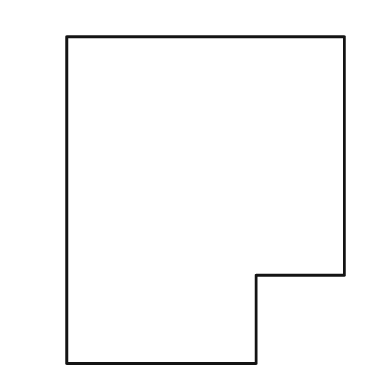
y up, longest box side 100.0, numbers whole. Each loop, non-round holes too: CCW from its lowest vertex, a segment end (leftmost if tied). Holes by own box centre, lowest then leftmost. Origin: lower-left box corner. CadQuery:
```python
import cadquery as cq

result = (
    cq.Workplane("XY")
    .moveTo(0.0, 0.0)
    .lineTo(58.0, 0.0)
    .lineTo(58.0, 27.0)
    .lineTo(85.0, 27.0)
    .lineTo(85.0, 100.0)
    .lineTo(0.0, 100.0)
    .close()
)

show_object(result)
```